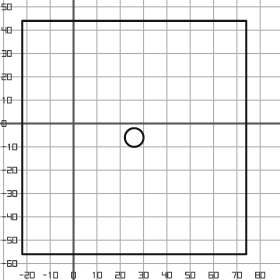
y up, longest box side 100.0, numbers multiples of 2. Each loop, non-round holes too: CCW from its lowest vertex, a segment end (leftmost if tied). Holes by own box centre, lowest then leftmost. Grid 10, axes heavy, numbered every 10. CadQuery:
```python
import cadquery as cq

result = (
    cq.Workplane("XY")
    .moveTo(-22.0, -56.0)
    .lineTo(74.0, -56.0)
    .lineTo(74.0, 44.0)
    .lineTo(-22.0, 44.0)
    .close()
    .moveTo(26.0, -6.0)
    .circle(4.0)
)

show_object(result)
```